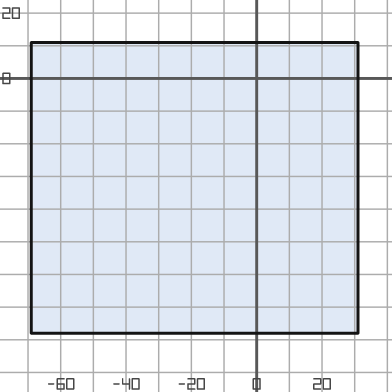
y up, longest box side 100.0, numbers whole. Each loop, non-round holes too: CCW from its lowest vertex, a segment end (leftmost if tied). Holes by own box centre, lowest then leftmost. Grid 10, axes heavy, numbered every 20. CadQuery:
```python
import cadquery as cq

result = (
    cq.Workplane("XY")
    .moveTo(-69.0, -78.0)
    .lineTo(31.0, -78.0)
    .lineTo(31.0, 11.0)
    .lineTo(-69.0, 11.0)
    .close()
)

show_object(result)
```